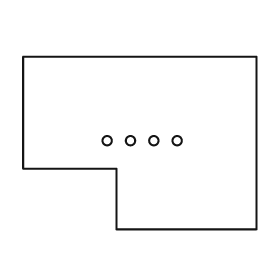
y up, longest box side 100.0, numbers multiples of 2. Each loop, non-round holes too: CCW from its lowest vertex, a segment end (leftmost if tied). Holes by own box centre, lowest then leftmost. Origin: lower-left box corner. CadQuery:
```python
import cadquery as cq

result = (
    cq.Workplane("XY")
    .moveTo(40.0, 0.0)
    .lineTo(100.0, 0.0)
    .lineTo(100.0, 74.0)
    .lineTo(0.0, 74.0)
    .lineTo(0.0, 26.0)
    .lineTo(40.0, 26.0)
    .close()
    .moveTo(36.0, 38.0)
    .circle(2.0)
    .moveTo(46.0, 38.0)
    .circle(2.0)
    .moveTo(56.0, 38.0)
    .circle(2.0)
    .moveTo(66.0, 38.0)
    .circle(2.0)
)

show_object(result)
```